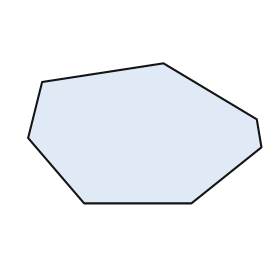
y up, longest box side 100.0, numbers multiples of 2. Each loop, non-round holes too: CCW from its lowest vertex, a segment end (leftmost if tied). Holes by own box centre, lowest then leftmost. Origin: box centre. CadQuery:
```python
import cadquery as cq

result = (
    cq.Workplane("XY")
    .moveTo(-26.0, -30.0)
    .lineTo(20.0, -30.0)
    .lineTo(50.0, -6.0)
    .lineTo(48.0, 6.0)
    .lineTo(8.0, 30.0)
    .lineTo(-44.0, 22.0)
    .lineTo(-50.0, -2.0)
    .close()
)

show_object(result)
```